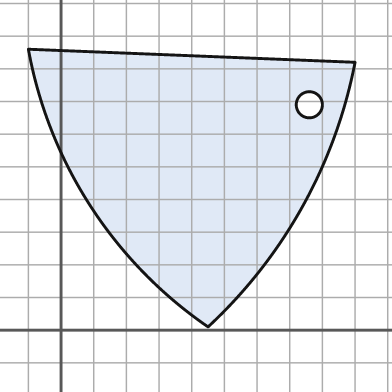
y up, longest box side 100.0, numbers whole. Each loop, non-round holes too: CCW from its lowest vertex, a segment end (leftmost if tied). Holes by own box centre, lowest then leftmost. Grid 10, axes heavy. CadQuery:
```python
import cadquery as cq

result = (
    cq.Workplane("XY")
    .moveTo(45.0, 1.0)
    .threePointArc((74.0, 38.0), (90.0, 82.0))
    .lineTo(-10.0, 86.0)
    .threePointArc((9.0, 38.0), (45.0, 1.0))
    .close()
    .moveTo(76.0, 69.0)
    .circle(4.0)
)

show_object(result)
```